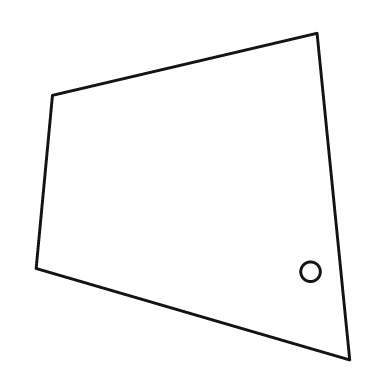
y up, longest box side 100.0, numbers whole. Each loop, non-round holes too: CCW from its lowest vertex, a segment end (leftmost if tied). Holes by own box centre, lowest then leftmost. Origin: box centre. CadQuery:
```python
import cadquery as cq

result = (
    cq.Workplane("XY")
    .moveTo(48.0, -50.0)
    .lineTo(38.0, 50.0)
    .lineTo(-43.0, 31.0)
    .lineTo(-48.0, -22.0)
    .close()
    .moveTo(36.0, -23.0)
    .circle(3.0)
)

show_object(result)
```